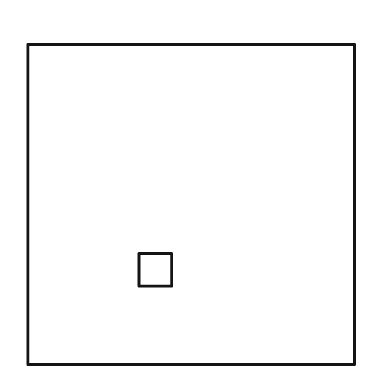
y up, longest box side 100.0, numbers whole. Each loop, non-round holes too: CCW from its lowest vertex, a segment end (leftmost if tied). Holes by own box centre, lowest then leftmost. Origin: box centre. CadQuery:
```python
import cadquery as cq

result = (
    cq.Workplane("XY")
    .moveTo(-50.0, -49.0)
    .lineTo(50.0, -49.0)
    .lineTo(50.0, 49.0)
    .lineTo(-50.0, 49.0)
    .close()
    .moveTo(-16.0, -25.0)
    .lineTo(-6.0, -25.0)
    .lineTo(-6.0, -15.0)
    .lineTo(-16.0, -15.0)
    .close()
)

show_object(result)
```